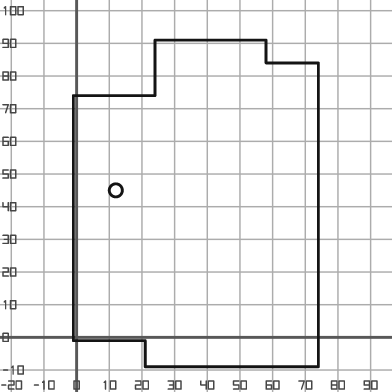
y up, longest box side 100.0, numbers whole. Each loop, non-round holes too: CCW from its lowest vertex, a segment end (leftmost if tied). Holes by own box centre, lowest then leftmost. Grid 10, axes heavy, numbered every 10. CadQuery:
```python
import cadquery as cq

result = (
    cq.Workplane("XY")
    .moveTo(21.0, -9.0)
    .lineTo(74.0, -9.0)
    .lineTo(74.0, 84.0)
    .lineTo(58.0, 84.0)
    .lineTo(58.0, 91.0)
    .lineTo(24.0, 91.0)
    .lineTo(24.0, 74.0)
    .lineTo(-1.0, 74.0)
    .lineTo(-1.0, -1.0)
    .lineTo(21.0, -1.0)
    .close()
    .moveTo(12.0, 45.0)
    .circle(2.0)
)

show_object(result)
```